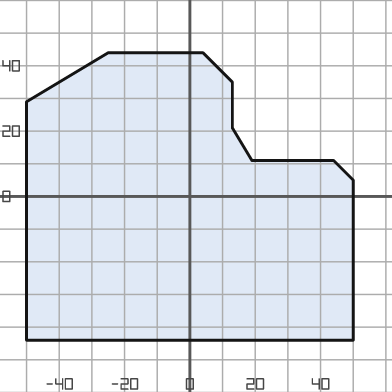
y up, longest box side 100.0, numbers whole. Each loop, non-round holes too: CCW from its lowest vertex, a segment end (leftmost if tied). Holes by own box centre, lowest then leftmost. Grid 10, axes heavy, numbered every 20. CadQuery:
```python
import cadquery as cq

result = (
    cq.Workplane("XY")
    .moveTo(-50.0, -44.0)
    .lineTo(50.0, -44.0)
    .lineTo(50.0, 5.0)
    .lineTo(44.0, 11.0)
    .lineTo(19.0, 11.0)
    .lineTo(13.0, 21.0)
    .lineTo(13.0, 35.0)
    .lineTo(4.0, 44.0)
    .lineTo(-25.0, 44.0)
    .lineTo(-50.0, 29.0)
    .close()
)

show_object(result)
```